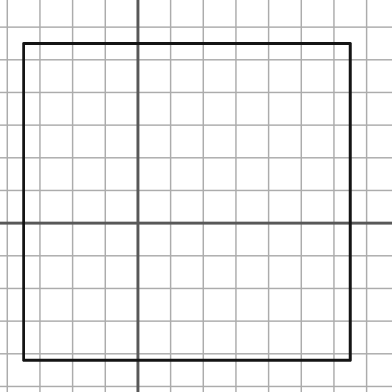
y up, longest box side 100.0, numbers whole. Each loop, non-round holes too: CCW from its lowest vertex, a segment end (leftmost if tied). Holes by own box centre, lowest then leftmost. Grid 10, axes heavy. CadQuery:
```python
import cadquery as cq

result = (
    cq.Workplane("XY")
    .moveTo(-35.0, -42.0)
    .lineTo(65.0, -42.0)
    .lineTo(65.0, 55.0)
    .lineTo(-35.0, 55.0)
    .close()
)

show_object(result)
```